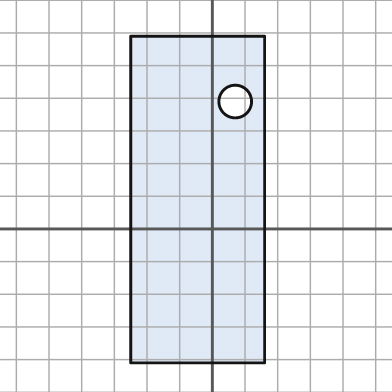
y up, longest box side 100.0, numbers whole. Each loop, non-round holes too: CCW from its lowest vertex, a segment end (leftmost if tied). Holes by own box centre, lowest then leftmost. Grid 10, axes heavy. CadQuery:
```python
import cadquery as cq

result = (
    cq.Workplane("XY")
    .moveTo(-25.0, -41.0)
    .lineTo(16.0, -41.0)
    .lineTo(16.0, 59.0)
    .lineTo(-25.0, 59.0)
    .close()
    .moveTo(7.0, 39.0)
    .circle(5.0)
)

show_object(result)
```